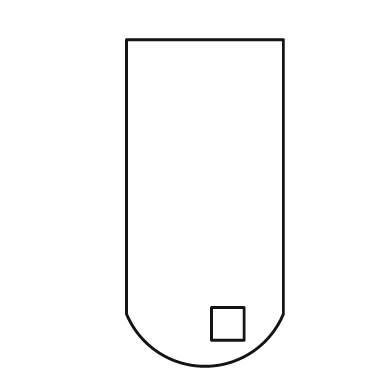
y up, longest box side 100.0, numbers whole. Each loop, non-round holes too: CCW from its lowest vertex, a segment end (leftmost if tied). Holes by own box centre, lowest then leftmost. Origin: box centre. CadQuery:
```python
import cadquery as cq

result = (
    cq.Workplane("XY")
    .moveTo(-24.0, -34.0)
    .threePointArc((0.0, -50.0), (24.0, -34.0))
    .lineTo(24.0, 50.0)
    .lineTo(-24.0, 50.0)
    .close()
    .moveTo(2.0, -42.0)
    .lineTo(12.0, -42.0)
    .lineTo(12.0, -32.0)
    .lineTo(2.0, -32.0)
    .close()
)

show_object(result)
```